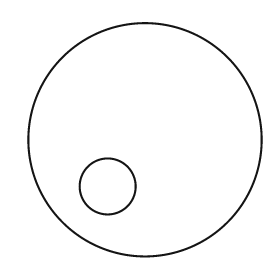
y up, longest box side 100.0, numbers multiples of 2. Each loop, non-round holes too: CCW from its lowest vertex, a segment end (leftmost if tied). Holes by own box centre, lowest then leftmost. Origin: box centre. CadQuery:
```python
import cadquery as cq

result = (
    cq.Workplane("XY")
    .moveTo(0.0, 0.0)
    .circle(50.0)
    .moveTo(-16.0, -20.0)
    .circle(12.0)
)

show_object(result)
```